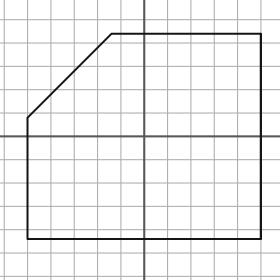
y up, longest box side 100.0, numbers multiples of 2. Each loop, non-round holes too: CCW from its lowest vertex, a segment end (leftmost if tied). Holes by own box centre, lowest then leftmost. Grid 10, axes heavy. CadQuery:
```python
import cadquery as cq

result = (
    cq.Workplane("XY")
    .moveTo(-50.0, -44.0)
    .lineTo(50.0, -44.0)
    .lineTo(50.0, 44.0)
    .lineTo(-14.0, 44.0)
    .lineTo(-50.0, 8.0)
    .close()
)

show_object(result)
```